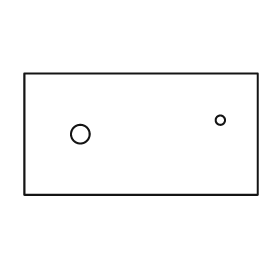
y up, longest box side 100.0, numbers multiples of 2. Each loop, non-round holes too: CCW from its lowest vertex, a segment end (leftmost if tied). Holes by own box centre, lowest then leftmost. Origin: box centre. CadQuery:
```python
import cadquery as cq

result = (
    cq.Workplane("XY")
    .moveTo(-50.0, -26.0)
    .lineTo(50.0, -26.0)
    .lineTo(50.0, 26.0)
    .lineTo(-50.0, 26.0)
    .close()
    .moveTo(-26.0, 0.0)
    .circle(4.0)
    .moveTo(34.0, 6.0)
    .circle(2.0)
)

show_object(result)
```